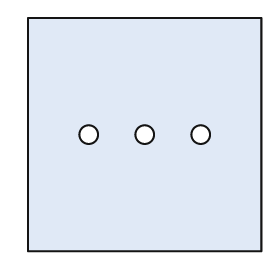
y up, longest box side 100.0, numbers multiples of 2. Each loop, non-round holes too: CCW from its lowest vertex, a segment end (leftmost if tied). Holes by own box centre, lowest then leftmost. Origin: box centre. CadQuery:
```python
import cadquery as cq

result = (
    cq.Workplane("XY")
    .moveTo(-50.0, -50.0)
    .lineTo(50.0, -50.0)
    .lineTo(50.0, 50.0)
    .lineTo(-50.0, 50.0)
    .close()
    .moveTo(-24.0, 0.0)
    .circle(4.0)
    .moveTo(0.0, 0.0)
    .circle(4.0)
    .moveTo(24.0, 0.0)
    .circle(4.0)
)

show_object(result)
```